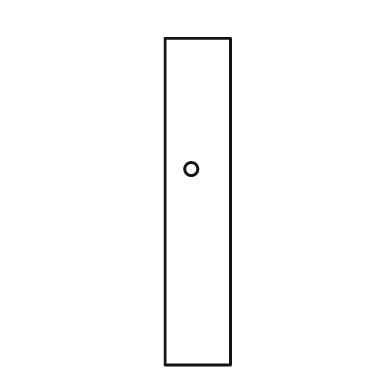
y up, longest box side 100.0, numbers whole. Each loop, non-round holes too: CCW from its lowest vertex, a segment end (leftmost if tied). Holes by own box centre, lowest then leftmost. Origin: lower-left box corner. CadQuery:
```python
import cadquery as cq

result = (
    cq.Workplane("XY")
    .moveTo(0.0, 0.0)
    .lineTo(20.0, 0.0)
    .lineTo(20.0, 100.0)
    .lineTo(0.0, 100.0)
    .close()
    .moveTo(8.0, 60.0)
    .circle(2.0)
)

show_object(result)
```